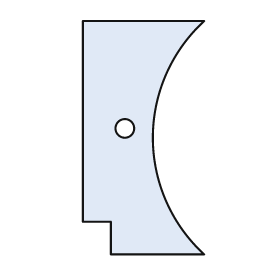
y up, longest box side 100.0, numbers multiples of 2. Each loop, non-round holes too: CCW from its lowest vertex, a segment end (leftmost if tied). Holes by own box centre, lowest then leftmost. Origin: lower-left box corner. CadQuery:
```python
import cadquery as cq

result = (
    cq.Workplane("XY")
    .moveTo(12.0, 0.0)
    .lineTo(52.0, 0.0)
    .threePointArc((30.0, 50.0), (52.0, 100.0))
    .lineTo(0.0, 100.0)
    .lineTo(0.0, 14.0)
    .lineTo(12.0, 14.0)
    .close()
    .moveTo(18.0, 54.0)
    .circle(4.0)
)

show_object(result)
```